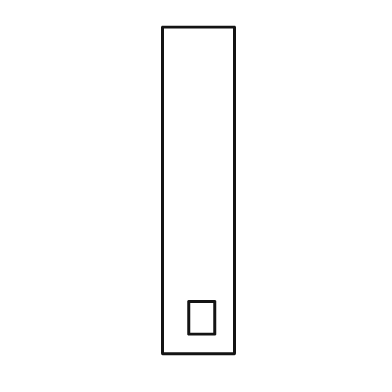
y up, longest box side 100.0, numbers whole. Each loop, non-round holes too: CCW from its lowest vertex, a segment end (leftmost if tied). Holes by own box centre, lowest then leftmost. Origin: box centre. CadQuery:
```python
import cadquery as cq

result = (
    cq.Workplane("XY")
    .moveTo(-11.0, -50.0)
    .lineTo(11.0, -50.0)
    .lineTo(11.0, 50.0)
    .lineTo(-11.0, 50.0)
    .close()
    .moveTo(-3.0, -44.0)
    .lineTo(5.0, -44.0)
    .lineTo(5.0, -34.0)
    .lineTo(-3.0, -34.0)
    .close()
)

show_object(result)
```